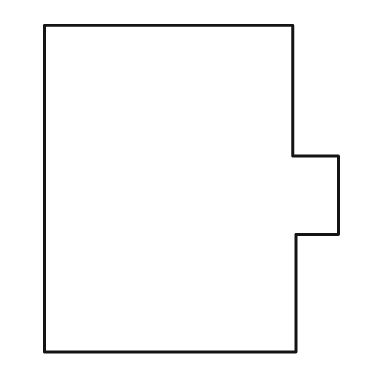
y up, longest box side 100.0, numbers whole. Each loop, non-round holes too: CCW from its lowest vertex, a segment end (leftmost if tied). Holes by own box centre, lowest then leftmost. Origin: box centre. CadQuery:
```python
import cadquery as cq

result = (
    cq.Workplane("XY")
    .moveTo(-45.0, -50.0)
    .lineTo(32.0, -50.0)
    .lineTo(32.0, -14.0)
    .lineTo(45.0, -14.0)
    .lineTo(45.0, 10.0)
    .lineTo(31.0, 10.0)
    .lineTo(31.0, 50.0)
    .lineTo(-45.0, 50.0)
    .close()
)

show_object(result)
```